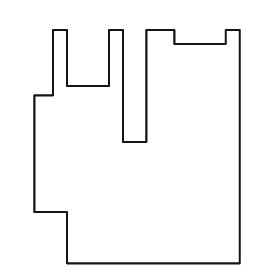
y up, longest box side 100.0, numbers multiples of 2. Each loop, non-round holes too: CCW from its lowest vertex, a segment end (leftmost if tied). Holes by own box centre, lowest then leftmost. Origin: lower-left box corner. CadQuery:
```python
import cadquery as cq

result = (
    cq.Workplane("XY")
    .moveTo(14.0, 0.0)
    .lineTo(88.0, 0.0)
    .lineTo(88.0, 100.0)
    .lineTo(82.0, 100.0)
    .lineTo(82.0, 94.0)
    .lineTo(60.0, 94.0)
    .lineTo(60.0, 100.0)
    .lineTo(48.0, 100.0)
    .lineTo(48.0, 52.0)
    .lineTo(38.0, 52.0)
    .lineTo(38.0, 100.0)
    .lineTo(32.0, 100.0)
    .lineTo(32.0, 76.0)
    .lineTo(14.0, 76.0)
    .lineTo(14.0, 100.0)
    .lineTo(8.0, 100.0)
    .lineTo(8.0, 72.0)
    .lineTo(0.0, 72.0)
    .lineTo(0.0, 22.0)
    .lineTo(14.0, 22.0)
    .close()
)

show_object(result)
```